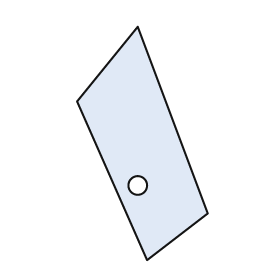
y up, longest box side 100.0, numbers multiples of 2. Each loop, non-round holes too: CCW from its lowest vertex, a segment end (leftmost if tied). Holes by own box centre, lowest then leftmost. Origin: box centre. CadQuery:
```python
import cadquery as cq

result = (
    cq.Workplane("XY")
    .moveTo(2.0, -50.0)
    .lineTo(28.0, -30.0)
    .lineTo(-2.0, 50.0)
    .lineTo(-28.0, 18.0)
    .close()
    .moveTo(-2.0, -18.0)
    .circle(4.0)
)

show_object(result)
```